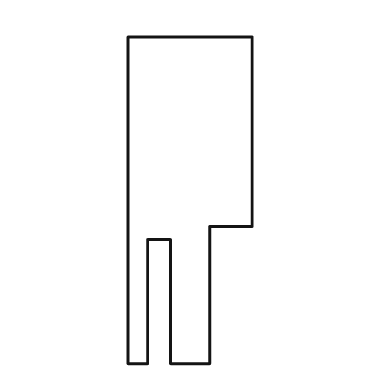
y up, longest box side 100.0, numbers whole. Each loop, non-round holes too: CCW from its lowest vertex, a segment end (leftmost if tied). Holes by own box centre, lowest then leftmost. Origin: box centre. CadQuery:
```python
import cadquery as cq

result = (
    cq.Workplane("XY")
    .moveTo(-19.0, -50.0)
    .lineTo(-13.0, -50.0)
    .lineTo(-13.0, -12.0)
    .lineTo(-6.0, -12.0)
    .lineTo(-6.0, -50.0)
    .lineTo(6.0, -50.0)
    .lineTo(6.0, -8.0)
    .lineTo(19.0, -8.0)
    .lineTo(19.0, 50.0)
    .lineTo(-19.0, 50.0)
    .close()
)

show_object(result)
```